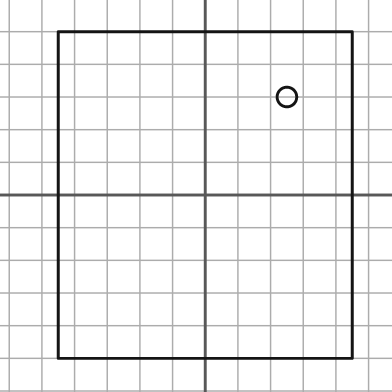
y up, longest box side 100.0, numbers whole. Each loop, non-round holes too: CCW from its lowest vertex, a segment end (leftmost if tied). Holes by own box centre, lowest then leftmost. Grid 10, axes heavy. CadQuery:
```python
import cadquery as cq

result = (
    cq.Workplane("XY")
    .moveTo(-45.0, -50.0)
    .lineTo(45.0, -50.0)
    .lineTo(45.0, 50.0)
    .lineTo(-45.0, 50.0)
    .close()
    .moveTo(25.0, 30.0)
    .circle(3.0)
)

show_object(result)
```